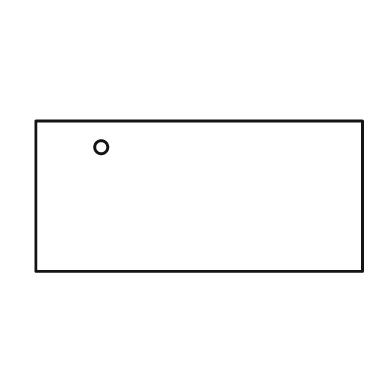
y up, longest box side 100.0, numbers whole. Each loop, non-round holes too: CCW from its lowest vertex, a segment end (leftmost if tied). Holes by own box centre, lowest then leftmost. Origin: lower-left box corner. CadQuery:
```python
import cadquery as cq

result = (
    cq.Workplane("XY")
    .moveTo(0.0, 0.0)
    .lineTo(100.0, 0.0)
    .lineTo(100.0, 46.0)
    .lineTo(0.0, 46.0)
    .close()
    .moveTo(20.0, 38.0)
    .circle(2.0)
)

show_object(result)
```